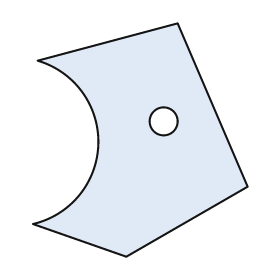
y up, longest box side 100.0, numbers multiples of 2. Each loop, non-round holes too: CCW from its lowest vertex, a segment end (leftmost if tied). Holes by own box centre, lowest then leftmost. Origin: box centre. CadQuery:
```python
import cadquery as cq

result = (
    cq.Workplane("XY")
    .moveTo(-6.0, -50.0)
    .lineTo(46.0, -20.0)
    .lineTo(16.0, 50.0)
    .lineTo(-44.0, 34.0)
    .threePointArc((-18.0, -2.0), (-46.0, -36.0))
    .close()
    .moveTo(10.0, 8.0)
    .circle(6.0)
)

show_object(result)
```